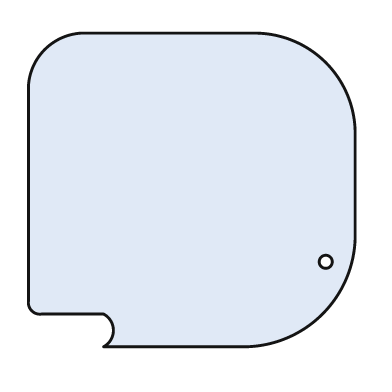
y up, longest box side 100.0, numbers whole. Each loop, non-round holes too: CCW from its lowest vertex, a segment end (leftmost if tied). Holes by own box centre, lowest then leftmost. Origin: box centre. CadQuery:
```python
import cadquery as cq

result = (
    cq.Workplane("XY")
    .moveTo(-27.0, -48.0)
    .lineTo(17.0, -48.0)
    .threePointArc((40.0, -38.0), (50.0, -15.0))
    .lineTo(50.0, 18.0)
    .threePointArc((41.0, 39.0), (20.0, 48.0))
    .lineTo(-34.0, 48.0)
    .threePointArc((-45.0, 43.0), (-50.0, 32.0))
    .lineTo(-50.0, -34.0)
    .threePointArc((-49.0, -37.0), (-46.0, -38.0))
    .lineTo(-27.0, -38.0)
    .threePointArc((-24.0, -43.0), (-27.0, -48.0))
    .close()
    .moveTo(41.0, -22.0)
    .circle(2.0)
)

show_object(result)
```